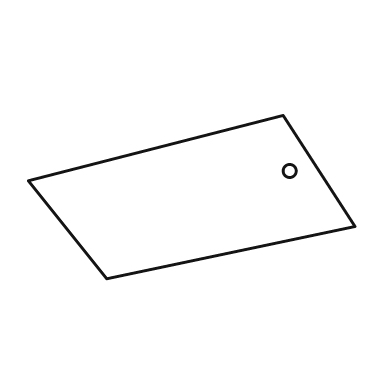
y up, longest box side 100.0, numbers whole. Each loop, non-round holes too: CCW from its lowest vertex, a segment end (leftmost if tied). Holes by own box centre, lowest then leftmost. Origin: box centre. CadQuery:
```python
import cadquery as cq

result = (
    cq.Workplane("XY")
    .moveTo(-26.0, -25.0)
    .lineTo(50.0, -9.0)
    .lineTo(28.0, 25.0)
    .lineTo(-50.0, 5.0)
    .close()
    .moveTo(30.0, 8.0)
    .circle(2.0)
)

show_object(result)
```